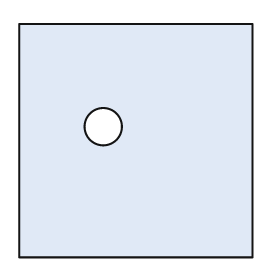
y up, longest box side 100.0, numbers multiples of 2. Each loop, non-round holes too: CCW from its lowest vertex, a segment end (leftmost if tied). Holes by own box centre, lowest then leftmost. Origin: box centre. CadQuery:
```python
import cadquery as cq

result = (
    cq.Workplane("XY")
    .moveTo(-50.0, -50.0)
    .lineTo(50.0, -50.0)
    .lineTo(50.0, 50.0)
    .lineTo(-50.0, 50.0)
    .close()
    .moveTo(-14.0, 6.0)
    .circle(8.0)
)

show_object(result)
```